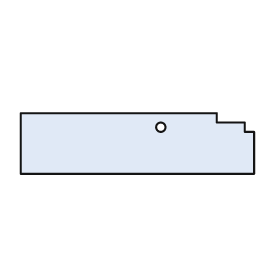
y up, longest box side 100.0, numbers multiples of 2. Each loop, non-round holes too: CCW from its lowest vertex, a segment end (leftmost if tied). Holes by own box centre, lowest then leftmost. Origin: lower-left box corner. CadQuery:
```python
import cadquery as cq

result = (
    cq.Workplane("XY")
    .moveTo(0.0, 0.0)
    .lineTo(100.0, 0.0)
    .lineTo(100.0, 18.0)
    .lineTo(96.0, 18.0)
    .lineTo(96.0, 22.0)
    .lineTo(84.0, 22.0)
    .lineTo(84.0, 26.0)
    .lineTo(0.0, 26.0)
    .close()
    .moveTo(60.0, 20.0)
    .circle(2.0)
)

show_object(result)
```